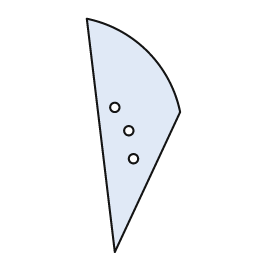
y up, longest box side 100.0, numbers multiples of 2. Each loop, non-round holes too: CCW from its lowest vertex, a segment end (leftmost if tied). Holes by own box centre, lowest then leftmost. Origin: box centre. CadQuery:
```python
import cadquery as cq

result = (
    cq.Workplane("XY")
    .moveTo(-8.0, -50.0)
    .lineTo(20.0, 10.0)
    .threePointArc((6.0, 36.0), (-20.0, 50.0))
    .close()
    .moveTo(0.0, -10.0)
    .circle(2.0)
    .moveTo(-2.0, 2.0)
    .circle(2.0)
    .moveTo(-8.0, 12.0)
    .circle(2.0)
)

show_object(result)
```